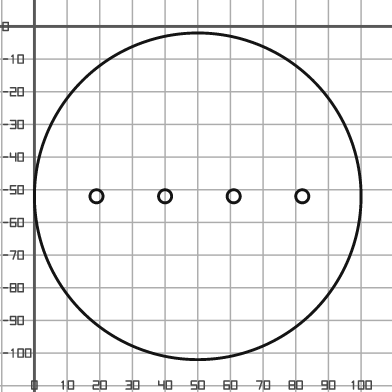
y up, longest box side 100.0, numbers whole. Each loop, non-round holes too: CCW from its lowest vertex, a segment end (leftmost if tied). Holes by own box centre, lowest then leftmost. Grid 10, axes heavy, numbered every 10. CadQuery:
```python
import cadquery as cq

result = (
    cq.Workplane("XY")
    .moveTo(50.0, -52.0)
    .circle(50.0)
    .moveTo(19.0, -52.0)
    .circle(2.0)
    .moveTo(40.0, -52.0)
    .circle(2.0)
    .moveTo(61.0, -52.0)
    .circle(2.0)
    .moveTo(82.0, -52.0)
    .circle(2.0)
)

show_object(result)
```